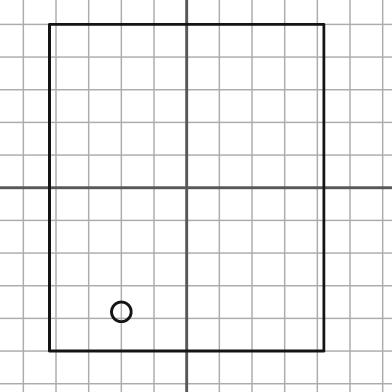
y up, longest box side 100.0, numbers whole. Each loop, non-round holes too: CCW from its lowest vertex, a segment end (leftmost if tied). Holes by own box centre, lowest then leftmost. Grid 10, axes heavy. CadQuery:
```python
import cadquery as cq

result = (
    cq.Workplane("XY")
    .moveTo(-42.0, -50.0)
    .lineTo(42.0, -50.0)
    .lineTo(42.0, 50.0)
    .lineTo(-42.0, 50.0)
    .close()
    .moveTo(-20.0, -38.0)
    .circle(3.0)
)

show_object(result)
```